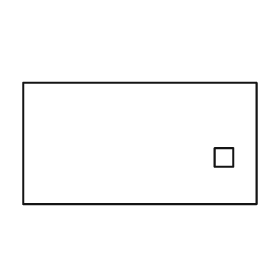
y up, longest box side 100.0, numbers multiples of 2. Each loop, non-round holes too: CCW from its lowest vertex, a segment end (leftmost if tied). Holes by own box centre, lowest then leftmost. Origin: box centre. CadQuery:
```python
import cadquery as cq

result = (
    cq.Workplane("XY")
    .moveTo(-50.0, -26.0)
    .lineTo(50.0, -26.0)
    .lineTo(50.0, 26.0)
    .lineTo(-50.0, 26.0)
    .close()
    .moveTo(32.0, -10.0)
    .lineTo(40.0, -10.0)
    .lineTo(40.0, -2.0)
    .lineTo(32.0, -2.0)
    .close()
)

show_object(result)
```